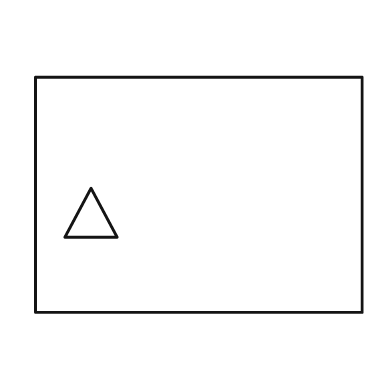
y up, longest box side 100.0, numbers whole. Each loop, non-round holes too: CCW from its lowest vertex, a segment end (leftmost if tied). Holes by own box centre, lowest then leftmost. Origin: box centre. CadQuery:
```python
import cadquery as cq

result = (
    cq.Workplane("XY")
    .moveTo(-50.0, -36.0)
    .lineTo(50.0, -36.0)
    .lineTo(50.0, 36.0)
    .lineTo(-50.0, 36.0)
    .close()
    .moveTo(-41.0, -13.0)
    .lineTo(-25.0, -13.0)
    .lineTo(-33.0, 2.0)
    .close()
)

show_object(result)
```